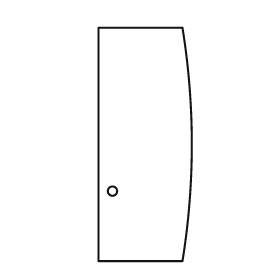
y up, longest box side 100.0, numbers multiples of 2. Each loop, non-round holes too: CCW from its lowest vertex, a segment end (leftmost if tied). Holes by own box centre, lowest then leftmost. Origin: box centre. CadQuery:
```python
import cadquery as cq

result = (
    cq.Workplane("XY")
    .moveTo(-20.0, -50.0)
    .lineTo(16.0, -50.0)
    .threePointArc((20.0, 0.0), (16.0, 50.0))
    .lineTo(-20.0, 50.0)
    .close()
    .moveTo(-14.0, -20.0)
    .circle(2.0)
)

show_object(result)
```